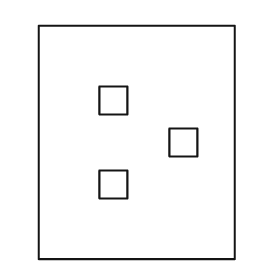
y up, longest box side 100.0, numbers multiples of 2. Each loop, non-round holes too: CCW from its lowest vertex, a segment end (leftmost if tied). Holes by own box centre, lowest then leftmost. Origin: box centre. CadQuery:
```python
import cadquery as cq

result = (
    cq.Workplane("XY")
    .moveTo(-42.0, -50.0)
    .lineTo(42.0, -50.0)
    .lineTo(42.0, 50.0)
    .lineTo(-42.0, 50.0)
    .close()
    .moveTo(-16.0, -24.0)
    .lineTo(-4.0, -24.0)
    .lineTo(-4.0, -12.0)
    .lineTo(-16.0, -12.0)
    .close()
    .moveTo(14.0, -6.0)
    .lineTo(26.0, -6.0)
    .lineTo(26.0, 6.0)
    .lineTo(14.0, 6.0)
    .close()
    .moveTo(-16.0, 12.0)
    .lineTo(-4.0, 12.0)
    .lineTo(-4.0, 24.0)
    .lineTo(-16.0, 24.0)
    .close()
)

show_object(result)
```